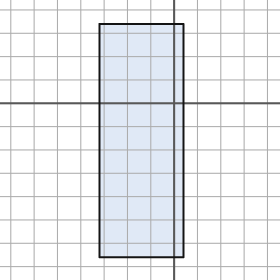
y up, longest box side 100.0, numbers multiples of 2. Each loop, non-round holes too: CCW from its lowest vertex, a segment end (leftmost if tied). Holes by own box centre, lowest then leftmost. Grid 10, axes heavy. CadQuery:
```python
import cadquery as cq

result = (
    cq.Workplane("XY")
    .moveTo(-32.0, -66.0)
    .lineTo(4.0, -66.0)
    .lineTo(4.0, 34.0)
    .lineTo(-32.0, 34.0)
    .close()
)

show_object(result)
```